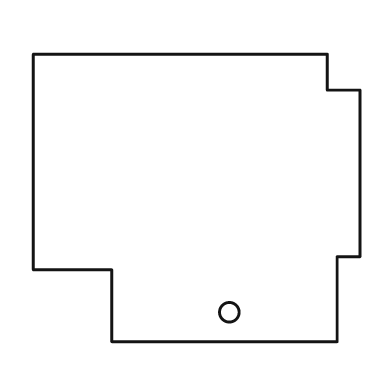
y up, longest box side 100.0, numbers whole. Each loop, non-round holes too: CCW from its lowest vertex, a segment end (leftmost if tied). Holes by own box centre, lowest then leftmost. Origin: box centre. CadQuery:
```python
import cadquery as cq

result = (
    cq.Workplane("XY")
    .moveTo(-26.0, -44.0)
    .lineTo(43.0, -44.0)
    .lineTo(43.0, -18.0)
    .lineTo(50.0, -18.0)
    .lineTo(50.0, 33.0)
    .lineTo(40.0, 33.0)
    .lineTo(40.0, 44.0)
    .lineTo(-50.0, 44.0)
    .lineTo(-50.0, -22.0)
    .lineTo(-26.0, -22.0)
    .close()
    .moveTo(10.0, -35.0)
    .circle(3.0)
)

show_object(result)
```